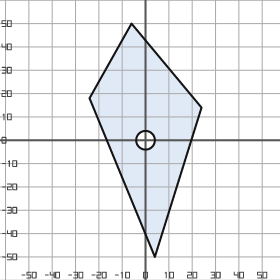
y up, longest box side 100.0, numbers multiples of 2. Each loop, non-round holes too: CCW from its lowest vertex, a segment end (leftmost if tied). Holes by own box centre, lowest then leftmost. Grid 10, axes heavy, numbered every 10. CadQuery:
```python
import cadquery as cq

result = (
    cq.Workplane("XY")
    .moveTo(4.0, -50.0)
    .lineTo(24.0, 14.0)
    .lineTo(-6.0, 50.0)
    .lineTo(-24.0, 18.0)
    .close()
    .moveTo(0.0, 0.0)
    .circle(4.0)
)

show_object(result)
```